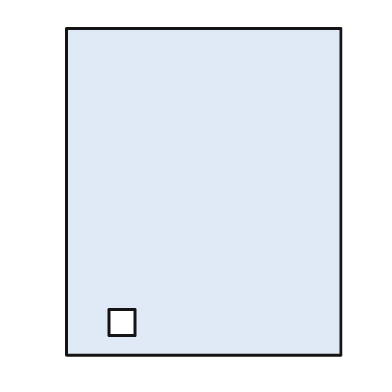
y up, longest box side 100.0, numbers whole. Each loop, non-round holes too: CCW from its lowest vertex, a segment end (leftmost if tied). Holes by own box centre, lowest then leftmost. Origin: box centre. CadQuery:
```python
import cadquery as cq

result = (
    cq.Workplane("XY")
    .moveTo(-42.0, -50.0)
    .lineTo(42.0, -50.0)
    .lineTo(42.0, 50.0)
    .lineTo(-42.0, 50.0)
    .close()
    .moveTo(-29.0, -44.0)
    .lineTo(-21.0, -44.0)
    .lineTo(-21.0, -36.0)
    .lineTo(-29.0, -36.0)
    .close()
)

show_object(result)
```